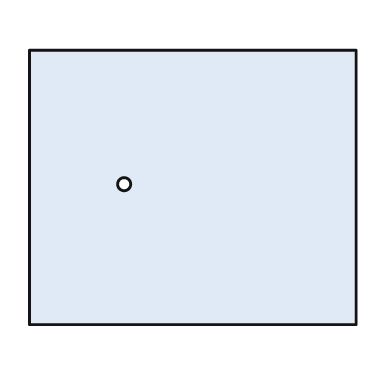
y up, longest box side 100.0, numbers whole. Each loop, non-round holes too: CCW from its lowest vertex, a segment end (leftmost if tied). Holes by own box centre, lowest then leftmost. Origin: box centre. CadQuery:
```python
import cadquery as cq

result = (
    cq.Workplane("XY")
    .moveTo(-50.0, -42.0)
    .lineTo(50.0, -42.0)
    .lineTo(50.0, 42.0)
    .lineTo(-50.0, 42.0)
    .close()
    .moveTo(-21.0, 1.0)
    .circle(2.0)
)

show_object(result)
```